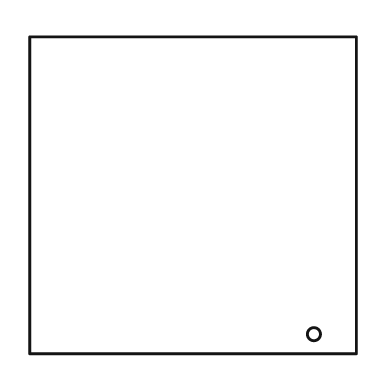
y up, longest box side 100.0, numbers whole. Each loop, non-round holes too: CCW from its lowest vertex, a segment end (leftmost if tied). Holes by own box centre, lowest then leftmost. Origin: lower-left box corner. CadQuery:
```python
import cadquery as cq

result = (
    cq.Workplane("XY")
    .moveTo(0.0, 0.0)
    .lineTo(100.0, 0.0)
    .lineTo(100.0, 97.0)
    .lineTo(0.0, 97.0)
    .close()
    .moveTo(87.0, 6.0)
    .circle(2.0)
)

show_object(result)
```